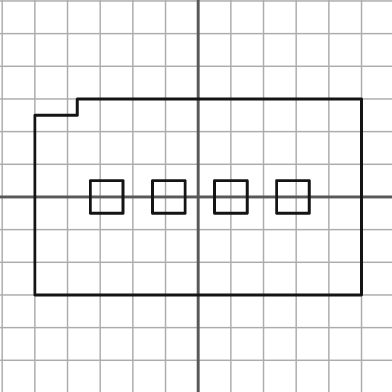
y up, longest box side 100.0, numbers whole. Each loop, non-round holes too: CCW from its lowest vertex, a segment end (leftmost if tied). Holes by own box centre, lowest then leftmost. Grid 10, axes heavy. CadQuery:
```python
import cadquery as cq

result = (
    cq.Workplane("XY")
    .moveTo(-50.0, -30.0)
    .lineTo(50.0, -30.0)
    .lineTo(50.0, 30.0)
    .lineTo(-37.0, 30.0)
    .lineTo(-37.0, 25.0)
    .lineTo(-50.0, 25.0)
    .close()
    .moveTo(-33.0, -5.0)
    .lineTo(-23.0, -5.0)
    .lineTo(-23.0, 5.0)
    .lineTo(-33.0, 5.0)
    .close()
    .moveTo(-14.0, -5.0)
    .lineTo(-4.0, -5.0)
    .lineTo(-4.0, 5.0)
    .lineTo(-14.0, 5.0)
    .close()
    .moveTo(5.0, -5.0)
    .lineTo(15.0, -5.0)
    .lineTo(15.0, 5.0)
    .lineTo(5.0, 5.0)
    .close()
    .moveTo(24.0, -5.0)
    .lineTo(34.0, -5.0)
    .lineTo(34.0, 5.0)
    .lineTo(24.0, 5.0)
    .close()
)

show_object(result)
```